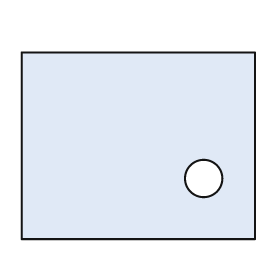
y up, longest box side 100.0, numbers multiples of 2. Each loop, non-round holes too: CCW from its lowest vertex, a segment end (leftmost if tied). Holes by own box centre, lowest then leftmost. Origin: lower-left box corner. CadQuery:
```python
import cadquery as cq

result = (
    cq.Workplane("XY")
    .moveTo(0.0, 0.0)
    .lineTo(100.0, 0.0)
    .lineTo(100.0, 80.0)
    .lineTo(0.0, 80.0)
    .close()
    .moveTo(78.0, 26.0)
    .circle(8.0)
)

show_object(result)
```